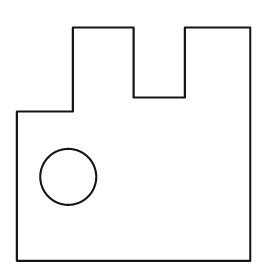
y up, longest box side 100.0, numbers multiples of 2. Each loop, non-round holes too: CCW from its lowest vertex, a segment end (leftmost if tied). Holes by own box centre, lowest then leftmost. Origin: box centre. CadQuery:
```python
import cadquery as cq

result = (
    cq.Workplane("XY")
    .moveTo(-50.0, -50.0)
    .lineTo(50.0, -50.0)
    .lineTo(50.0, 50.0)
    .lineTo(22.0, 50.0)
    .lineTo(22.0, 20.0)
    .lineTo(0.0, 20.0)
    .lineTo(0.0, 50.0)
    .lineTo(-26.0, 50.0)
    .lineTo(-26.0, 14.0)
    .lineTo(-50.0, 14.0)
    .close()
    .moveTo(-28.0, -14.0)
    .circle(12.0)
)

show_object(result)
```